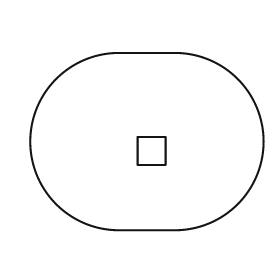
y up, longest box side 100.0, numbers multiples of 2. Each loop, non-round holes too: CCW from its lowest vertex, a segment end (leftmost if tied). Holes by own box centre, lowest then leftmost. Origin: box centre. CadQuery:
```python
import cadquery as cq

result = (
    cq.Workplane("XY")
    .moveTo(-12.0, -38.0)
    .lineTo(12.0, -38.0)
    .threePointArc((50.0, 0.0), (12.0, 38.0))
    .lineTo(-12.0, 38.0)
    .threePointArc((-50.0, 0.0), (-12.0, -38.0))
    .close()
    .moveTo(-4.0, -10.0)
    .lineTo(8.0, -10.0)
    .lineTo(8.0, 2.0)
    .lineTo(-4.0, 2.0)
    .close()
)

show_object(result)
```